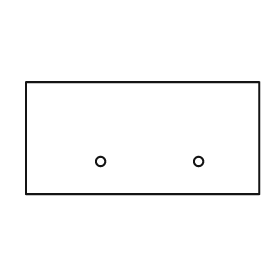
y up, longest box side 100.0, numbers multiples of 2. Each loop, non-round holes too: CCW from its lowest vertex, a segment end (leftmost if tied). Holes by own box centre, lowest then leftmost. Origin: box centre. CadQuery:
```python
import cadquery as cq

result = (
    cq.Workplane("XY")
    .moveTo(-50.0, -24.0)
    .lineTo(50.0, -24.0)
    .lineTo(50.0, 24.0)
    .lineTo(-50.0, 24.0)
    .close()
    .moveTo(-18.0, -10.0)
    .circle(2.0)
    .moveTo(24.0, -10.0)
    .circle(2.0)
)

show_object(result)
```